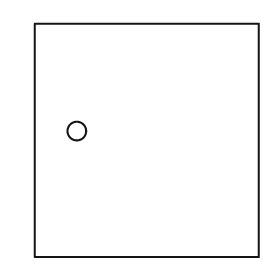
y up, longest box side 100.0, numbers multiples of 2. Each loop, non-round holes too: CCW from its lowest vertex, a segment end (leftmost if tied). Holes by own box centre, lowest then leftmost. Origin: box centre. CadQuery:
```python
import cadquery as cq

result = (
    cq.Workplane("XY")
    .moveTo(-48.0, -50.0)
    .lineTo(48.0, -50.0)
    .lineTo(48.0, 50.0)
    .lineTo(-48.0, 50.0)
    .close()
    .moveTo(-30.0, 4.0)
    .circle(4.0)
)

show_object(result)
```